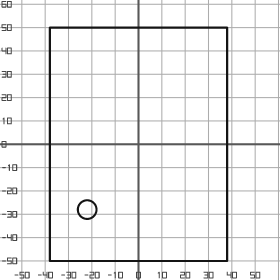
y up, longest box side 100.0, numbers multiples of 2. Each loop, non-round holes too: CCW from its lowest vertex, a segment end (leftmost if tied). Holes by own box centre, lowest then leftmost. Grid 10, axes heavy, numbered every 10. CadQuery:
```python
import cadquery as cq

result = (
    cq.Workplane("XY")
    .moveTo(-38.0, -50.0)
    .lineTo(38.0, -50.0)
    .lineTo(38.0, 50.0)
    .lineTo(-38.0, 50.0)
    .close()
    .moveTo(-22.0, -28.0)
    .circle(4.0)
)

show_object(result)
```